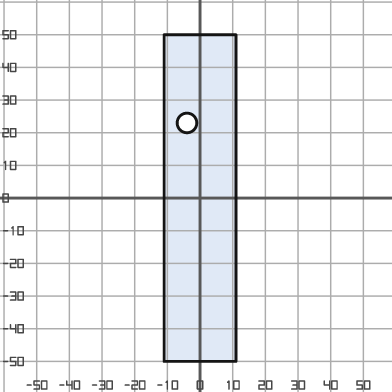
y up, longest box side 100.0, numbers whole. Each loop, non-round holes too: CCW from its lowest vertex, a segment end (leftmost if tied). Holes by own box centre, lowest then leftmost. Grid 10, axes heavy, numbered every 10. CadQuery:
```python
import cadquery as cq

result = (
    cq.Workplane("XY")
    .moveTo(-11.0, -50.0)
    .lineTo(11.0, -50.0)
    .lineTo(11.0, 50.0)
    .lineTo(-11.0, 50.0)
    .close()
    .moveTo(-4.0, 23.0)
    .circle(3.0)
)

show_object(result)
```